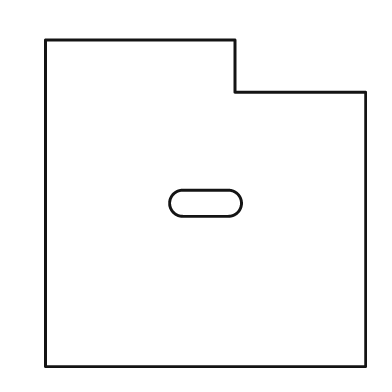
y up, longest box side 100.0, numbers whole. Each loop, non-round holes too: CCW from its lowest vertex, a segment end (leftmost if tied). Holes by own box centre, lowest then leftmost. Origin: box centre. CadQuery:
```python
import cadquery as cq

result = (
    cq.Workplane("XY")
    .moveTo(-49.0, -50.0)
    .lineTo(49.0, -50.0)
    .lineTo(49.0, 34.0)
    .lineTo(9.0, 34.0)
    .lineTo(9.0, 50.0)
    .lineTo(-49.0, 50.0)
    .close()
    .moveTo(-7.0, -4.0)
    .lineTo(7.0, -4.0)
    .threePointArc((11.0, 0.0), (7.0, 4.0))
    .lineTo(-7.0, 4.0)
    .threePointArc((-11.0, 0.0), (-7.0, -4.0))
    .close()
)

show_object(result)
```